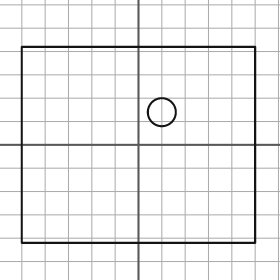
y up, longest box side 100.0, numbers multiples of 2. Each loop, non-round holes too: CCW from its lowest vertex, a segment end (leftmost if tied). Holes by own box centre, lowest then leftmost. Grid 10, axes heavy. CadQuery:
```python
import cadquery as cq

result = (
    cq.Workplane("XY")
    .moveTo(-50.0, -42.0)
    .lineTo(50.0, -42.0)
    .lineTo(50.0, 42.0)
    .lineTo(-50.0, 42.0)
    .close()
    .moveTo(10.0, 14.0)
    .circle(6.0)
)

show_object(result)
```